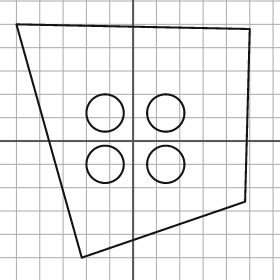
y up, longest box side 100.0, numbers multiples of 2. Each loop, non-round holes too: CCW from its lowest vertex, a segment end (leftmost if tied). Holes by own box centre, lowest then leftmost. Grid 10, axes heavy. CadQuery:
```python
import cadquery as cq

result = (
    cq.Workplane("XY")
    .moveTo(-22.0, -50.0)
    .lineTo(48.0, -26.0)
    .lineTo(50.0, 48.0)
    .lineTo(-50.0, 50.0)
    .close()
    .moveTo(-12.0, -10.0)
    .circle(8.0)
    .moveTo(14.0, -10.0)
    .circle(8.0)
    .moveTo(-12.0, 12.0)
    .circle(8.0)
    .moveTo(14.0, 12.0)
    .circle(8.0)
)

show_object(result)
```